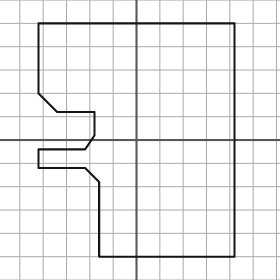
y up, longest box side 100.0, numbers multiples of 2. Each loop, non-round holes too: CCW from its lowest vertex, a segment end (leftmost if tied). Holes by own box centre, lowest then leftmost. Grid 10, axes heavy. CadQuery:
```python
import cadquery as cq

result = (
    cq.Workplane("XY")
    .moveTo(-16.0, -50.0)
    .lineTo(42.0, -50.0)
    .lineTo(42.0, 50.0)
    .lineTo(-42.0, 50.0)
    .lineTo(-42.0, 20.0)
    .lineTo(-34.0, 12.0)
    .lineTo(-18.0, 12.0)
    .lineTo(-18.0, 2.0)
    .lineTo(-22.0, -4.0)
    .lineTo(-42.0, -4.0)
    .lineTo(-42.0, -12.0)
    .lineTo(-22.0, -12.0)
    .lineTo(-16.0, -18.0)
    .close()
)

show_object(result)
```